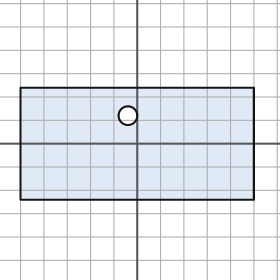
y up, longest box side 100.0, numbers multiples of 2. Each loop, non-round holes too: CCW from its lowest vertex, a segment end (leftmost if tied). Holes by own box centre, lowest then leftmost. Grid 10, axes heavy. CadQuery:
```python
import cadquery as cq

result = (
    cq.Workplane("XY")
    .moveTo(-50.0, -24.0)
    .lineTo(50.0, -24.0)
    .lineTo(50.0, 24.0)
    .lineTo(-50.0, 24.0)
    .close()
    .moveTo(-4.0, 12.0)
    .circle(4.0)
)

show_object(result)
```